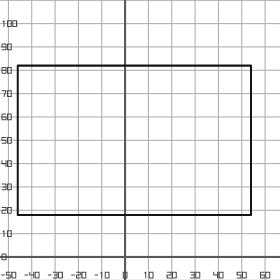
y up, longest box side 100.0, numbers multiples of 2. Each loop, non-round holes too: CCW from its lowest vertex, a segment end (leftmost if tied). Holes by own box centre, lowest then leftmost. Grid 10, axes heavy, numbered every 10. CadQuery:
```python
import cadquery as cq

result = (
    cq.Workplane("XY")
    .moveTo(-46.0, 18.0)
    .lineTo(54.0, 18.0)
    .lineTo(54.0, 82.0)
    .lineTo(-46.0, 82.0)
    .close()
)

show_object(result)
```